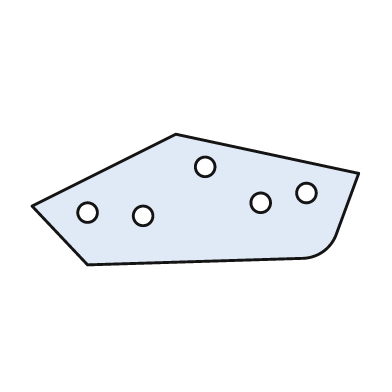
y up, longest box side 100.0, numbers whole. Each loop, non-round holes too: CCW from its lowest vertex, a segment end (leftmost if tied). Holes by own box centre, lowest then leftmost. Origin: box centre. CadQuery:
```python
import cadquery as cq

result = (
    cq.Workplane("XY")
    .moveTo(-33.0, -20.0)
    .lineTo(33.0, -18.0)
    .threePointArc((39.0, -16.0), (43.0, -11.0))
    .lineTo(50.0, 8.0)
    .lineTo(-6.0, 20.0)
    .lineTo(-50.0, -2.0)
    .close()
    .moveTo(-16.0, -5.0)
    .circle(3.0)
    .moveTo(-33.0, -4.0)
    .circle(3.0)
    .moveTo(20.0, -1.0)
    .circle(3.0)
    .moveTo(34.0, 2.0)
    .circle(3.0)
    .moveTo(3.0, 10.0)
    .circle(3.0)
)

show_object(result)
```